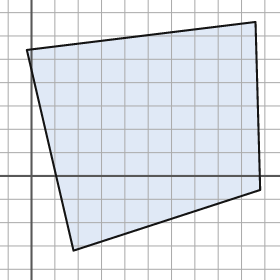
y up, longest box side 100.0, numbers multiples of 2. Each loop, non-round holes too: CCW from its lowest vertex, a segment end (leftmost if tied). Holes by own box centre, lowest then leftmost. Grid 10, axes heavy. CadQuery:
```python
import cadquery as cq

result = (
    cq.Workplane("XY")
    .moveTo(18.0, -32.0)
    .lineTo(98.0, -6.0)
    .lineTo(96.0, 66.0)
    .lineTo(-2.0, 54.0)
    .close()
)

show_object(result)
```